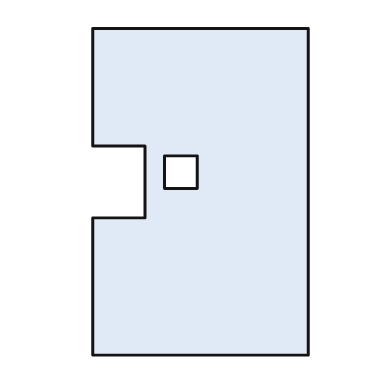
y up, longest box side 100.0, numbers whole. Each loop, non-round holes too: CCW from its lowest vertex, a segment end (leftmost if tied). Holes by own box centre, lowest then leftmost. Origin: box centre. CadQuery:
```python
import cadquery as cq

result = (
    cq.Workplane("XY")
    .moveTo(-33.0, -50.0)
    .lineTo(33.0, -50.0)
    .lineTo(33.0, 50.0)
    .lineTo(-33.0, 50.0)
    .lineTo(-33.0, 14.0)
    .lineTo(-17.0, 14.0)
    .lineTo(-17.0, -8.0)
    .lineTo(-33.0, -8.0)
    .close()
    .moveTo(-11.0, 1.0)
    .lineTo(-1.0, 1.0)
    .lineTo(-1.0, 11.0)
    .lineTo(-11.0, 11.0)
    .close()
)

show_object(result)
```